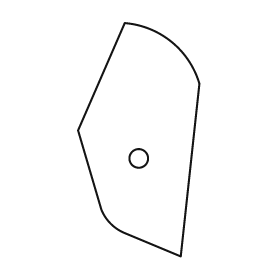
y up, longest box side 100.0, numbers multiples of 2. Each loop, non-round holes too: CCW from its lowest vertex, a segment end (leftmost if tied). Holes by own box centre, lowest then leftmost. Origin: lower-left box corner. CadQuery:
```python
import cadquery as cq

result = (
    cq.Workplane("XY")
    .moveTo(44.0, 0.0)
    .lineTo(52.0, 74.0)
    .threePointArc((40.0, 92.0), (20.0, 100.0))
    .lineTo(0.0, 54.0)
    .lineTo(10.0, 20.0)
    .threePointArc((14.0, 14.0), (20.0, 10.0))
    .close()
    .moveTo(26.0, 42.0)
    .circle(4.0)
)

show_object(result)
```